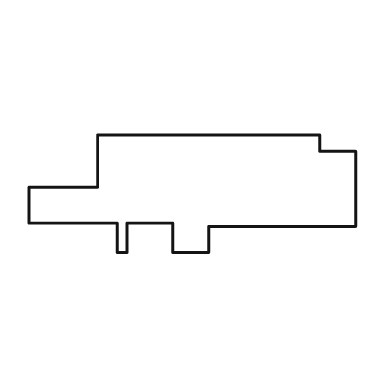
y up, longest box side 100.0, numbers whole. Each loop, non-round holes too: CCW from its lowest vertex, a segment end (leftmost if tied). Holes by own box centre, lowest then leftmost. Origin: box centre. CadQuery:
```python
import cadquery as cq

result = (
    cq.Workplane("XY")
    .moveTo(-23.0, -18.0)
    .lineTo(-20.0, -18.0)
    .lineTo(-20.0, -9.0)
    .lineTo(-6.0, -9.0)
    .lineTo(-6.0, -18.0)
    .lineTo(5.0, -18.0)
    .lineTo(5.0, -10.0)
    .lineTo(50.0, -10.0)
    .lineTo(50.0, 13.0)
    .lineTo(39.0, 13.0)
    .lineTo(39.0, 18.0)
    .lineTo(-29.0, 18.0)
    .lineTo(-29.0, 2.0)
    .lineTo(-50.0, 2.0)
    .lineTo(-50.0, -9.0)
    .lineTo(-23.0, -9.0)
    .close()
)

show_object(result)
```